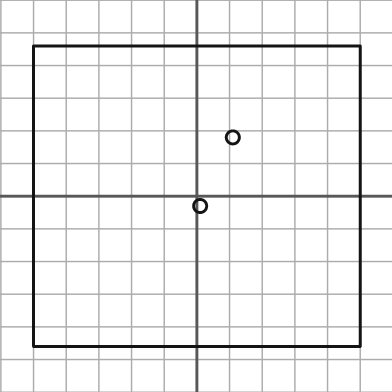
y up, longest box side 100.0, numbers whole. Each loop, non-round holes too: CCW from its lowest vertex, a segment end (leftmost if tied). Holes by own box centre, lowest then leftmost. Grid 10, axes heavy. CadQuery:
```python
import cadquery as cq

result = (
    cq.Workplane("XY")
    .moveTo(-50.0, -46.0)
    .lineTo(50.0, -46.0)
    .lineTo(50.0, 46.0)
    .lineTo(-50.0, 46.0)
    .close()
    .moveTo(1.0, -3.0)
    .circle(2.0)
    .moveTo(11.0, 18.0)
    .circle(2.0)
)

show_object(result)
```